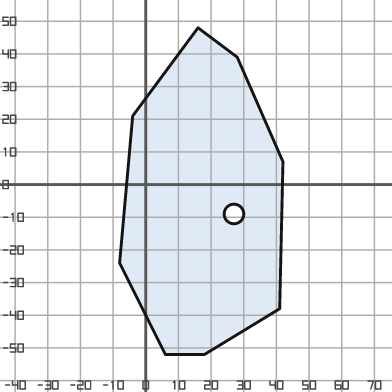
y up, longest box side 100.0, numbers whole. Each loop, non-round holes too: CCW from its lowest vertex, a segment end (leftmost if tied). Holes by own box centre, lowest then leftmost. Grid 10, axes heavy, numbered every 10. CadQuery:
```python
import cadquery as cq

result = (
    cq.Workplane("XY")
    .moveTo(6.0, -52.0)
    .lineTo(18.0, -52.0)
    .lineTo(41.0, -38.0)
    .lineTo(42.0, 7.0)
    .lineTo(28.0, 39.0)
    .lineTo(16.0, 48.0)
    .lineTo(-4.0, 21.0)
    .lineTo(-8.0, -24.0)
    .close()
    .moveTo(27.0, -9.0)
    .circle(3.0)
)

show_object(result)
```